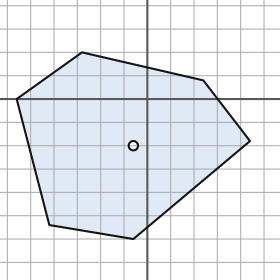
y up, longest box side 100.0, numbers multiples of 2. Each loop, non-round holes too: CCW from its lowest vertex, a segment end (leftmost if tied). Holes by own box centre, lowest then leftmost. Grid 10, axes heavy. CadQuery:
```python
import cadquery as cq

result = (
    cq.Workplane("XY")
    .moveTo(-6.0, -60.0)
    .lineTo(44.0, -18.0)
    .lineTo(24.0, 8.0)
    .lineTo(-28.0, 20.0)
    .lineTo(-56.0, 0.0)
    .lineTo(-42.0, -54.0)
    .close()
    .moveTo(-6.0, -20.0)
    .circle(2.0)
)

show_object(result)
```